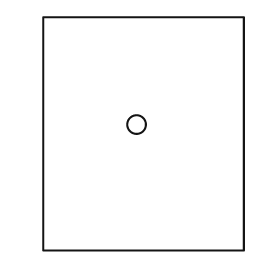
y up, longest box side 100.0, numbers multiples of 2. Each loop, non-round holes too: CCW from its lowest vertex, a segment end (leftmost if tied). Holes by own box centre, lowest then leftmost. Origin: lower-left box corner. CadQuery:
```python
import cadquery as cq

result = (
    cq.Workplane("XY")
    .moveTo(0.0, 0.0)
    .lineTo(86.0, 0.0)
    .lineTo(86.0, 100.0)
    .lineTo(0.0, 100.0)
    .close()
    .moveTo(40.0, 54.0)
    .circle(4.0)
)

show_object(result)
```